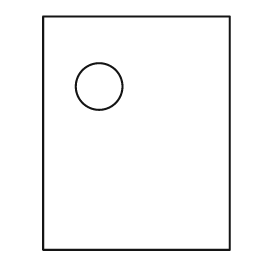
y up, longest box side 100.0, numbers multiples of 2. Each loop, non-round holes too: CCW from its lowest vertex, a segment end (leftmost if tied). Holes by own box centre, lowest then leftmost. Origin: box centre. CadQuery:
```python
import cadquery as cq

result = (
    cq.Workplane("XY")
    .moveTo(-40.0, -50.0)
    .lineTo(40.0, -50.0)
    .lineTo(40.0, 50.0)
    .lineTo(-40.0, 50.0)
    .close()
    .moveTo(-16.0, 20.0)
    .circle(10.0)
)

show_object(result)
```